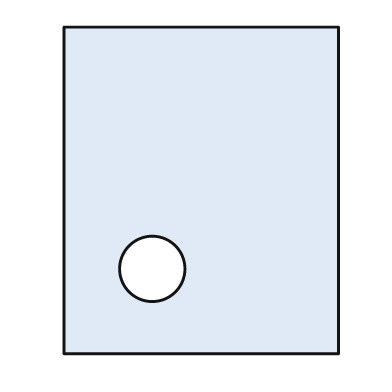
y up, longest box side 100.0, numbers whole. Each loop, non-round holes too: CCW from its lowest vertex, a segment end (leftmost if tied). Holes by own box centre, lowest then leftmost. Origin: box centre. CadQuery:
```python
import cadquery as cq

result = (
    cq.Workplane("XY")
    .moveTo(-42.0, -50.0)
    .lineTo(42.0, -50.0)
    .lineTo(42.0, 50.0)
    .lineTo(-42.0, 50.0)
    .close()
    .moveTo(-15.0, -24.0)
    .circle(10.0)
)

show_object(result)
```